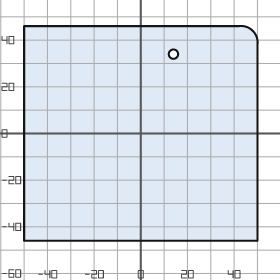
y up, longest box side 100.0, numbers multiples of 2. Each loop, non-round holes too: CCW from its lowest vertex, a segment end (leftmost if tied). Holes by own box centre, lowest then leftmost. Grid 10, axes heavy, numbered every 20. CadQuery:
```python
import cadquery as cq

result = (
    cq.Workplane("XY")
    .moveTo(-50.0, -46.0)
    .lineTo(50.0, -46.0)
    .lineTo(50.0, 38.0)
    .threePointArc((48.0, 44.0), (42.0, 46.0))
    .lineTo(-50.0, 46.0)
    .close()
    .moveTo(14.0, 34.0)
    .circle(2.0)
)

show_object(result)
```